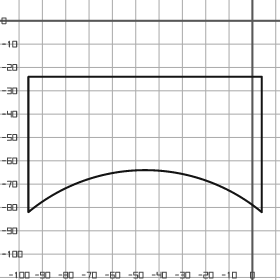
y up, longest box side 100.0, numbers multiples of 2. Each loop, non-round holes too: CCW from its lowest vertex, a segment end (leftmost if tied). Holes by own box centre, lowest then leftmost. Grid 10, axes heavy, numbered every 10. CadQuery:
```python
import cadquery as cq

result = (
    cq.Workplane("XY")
    .moveTo(-96.0, -82.0)
    .threePointArc((-46.0, -64.0), (4.0, -82.0))
    .lineTo(4.0, -24.0)
    .lineTo(-96.0, -24.0)
    .close()
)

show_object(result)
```